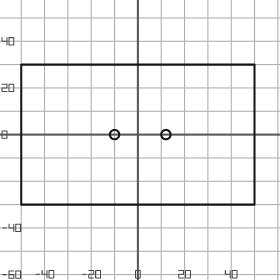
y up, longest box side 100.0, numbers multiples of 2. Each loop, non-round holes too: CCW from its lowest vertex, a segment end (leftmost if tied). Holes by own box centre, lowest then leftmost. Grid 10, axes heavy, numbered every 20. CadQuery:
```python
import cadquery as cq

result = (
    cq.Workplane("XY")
    .moveTo(-50.0, -30.0)
    .lineTo(50.0, -30.0)
    .lineTo(50.0, 30.0)
    .lineTo(-50.0, 30.0)
    .close()
    .moveTo(-10.0, 0.0)
    .circle(2.0)
    .moveTo(12.0, 0.0)
    .circle(2.0)
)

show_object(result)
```